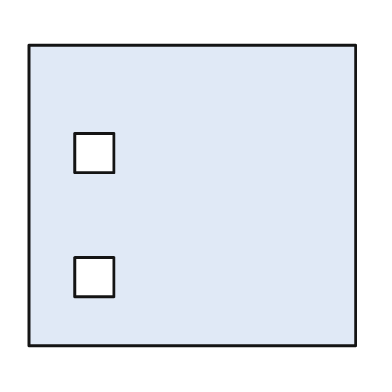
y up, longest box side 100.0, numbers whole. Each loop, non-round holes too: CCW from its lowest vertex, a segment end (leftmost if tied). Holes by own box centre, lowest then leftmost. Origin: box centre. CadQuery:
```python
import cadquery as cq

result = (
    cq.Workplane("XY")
    .moveTo(-50.0, -46.0)
    .lineTo(50.0, -46.0)
    .lineTo(50.0, 46.0)
    .lineTo(-50.0, 46.0)
    .close()
    .moveTo(-36.0, -31.0)
    .lineTo(-24.0, -31.0)
    .lineTo(-24.0, -19.0)
    .lineTo(-36.0, -19.0)
    .close()
    .moveTo(-36.0, 7.0)
    .lineTo(-24.0, 7.0)
    .lineTo(-24.0, 19.0)
    .lineTo(-36.0, 19.0)
    .close()
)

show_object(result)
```